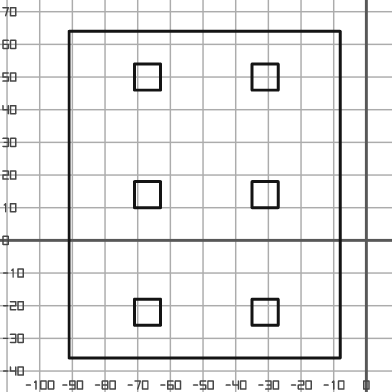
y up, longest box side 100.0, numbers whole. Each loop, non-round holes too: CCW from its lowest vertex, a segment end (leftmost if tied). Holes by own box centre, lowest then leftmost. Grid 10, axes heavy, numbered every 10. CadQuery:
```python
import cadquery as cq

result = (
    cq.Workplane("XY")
    .moveTo(-91.0, -36.0)
    .lineTo(-8.0, -36.0)
    .lineTo(-8.0, 64.0)
    .lineTo(-91.0, 64.0)
    .close()
    .moveTo(-71.0, -26.0)
    .lineTo(-63.0, -26.0)
    .lineTo(-63.0, -18.0)
    .lineTo(-71.0, -18.0)
    .close()
    .moveTo(-35.0, -26.0)
    .lineTo(-27.0, -26.0)
    .lineTo(-27.0, -18.0)
    .lineTo(-35.0, -18.0)
    .close()
    .moveTo(-71.0, 10.0)
    .lineTo(-63.0, 10.0)
    .lineTo(-63.0, 18.0)
    .lineTo(-71.0, 18.0)
    .close()
    .moveTo(-35.0, 10.0)
    .lineTo(-27.0, 10.0)
    .lineTo(-27.0, 18.0)
    .lineTo(-35.0, 18.0)
    .close()
    .moveTo(-71.0, 46.0)
    .lineTo(-63.0, 46.0)
    .lineTo(-63.0, 54.0)
    .lineTo(-71.0, 54.0)
    .close()
    .moveTo(-35.0, 46.0)
    .lineTo(-27.0, 46.0)
    .lineTo(-27.0, 54.0)
    .lineTo(-35.0, 54.0)
    .close()
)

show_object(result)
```